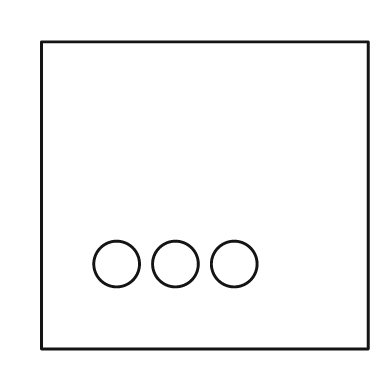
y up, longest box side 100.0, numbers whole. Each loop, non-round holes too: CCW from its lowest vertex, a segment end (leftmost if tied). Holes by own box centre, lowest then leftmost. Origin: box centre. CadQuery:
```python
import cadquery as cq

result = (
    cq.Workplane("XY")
    .moveTo(-50.0, -47.0)
    .lineTo(50.0, -47.0)
    .lineTo(50.0, 47.0)
    .lineTo(-50.0, 47.0)
    .close()
    .moveTo(-27.0, -21.0)
    .circle(7.0)
    .moveTo(-9.0, -21.0)
    .circle(7.0)
    .moveTo(9.0, -21.0)
    .circle(7.0)
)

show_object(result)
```